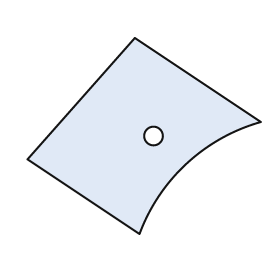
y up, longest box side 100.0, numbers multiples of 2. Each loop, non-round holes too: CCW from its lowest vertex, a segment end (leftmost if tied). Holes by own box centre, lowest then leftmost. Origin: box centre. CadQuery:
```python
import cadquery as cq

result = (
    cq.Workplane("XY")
    .moveTo(-2.0, -42.0)
    .threePointArc((18.0, -12.0), (50.0, 6.0))
    .lineTo(-4.0, 42.0)
    .lineTo(-50.0, -10.0)
    .close()
    .moveTo(4.0, 0.0)
    .circle(4.0)
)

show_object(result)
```